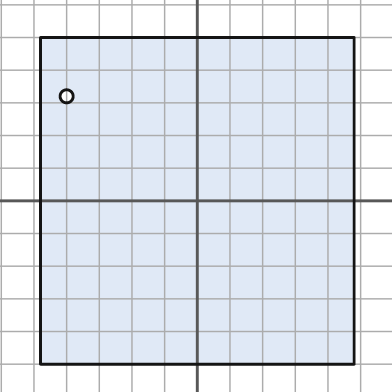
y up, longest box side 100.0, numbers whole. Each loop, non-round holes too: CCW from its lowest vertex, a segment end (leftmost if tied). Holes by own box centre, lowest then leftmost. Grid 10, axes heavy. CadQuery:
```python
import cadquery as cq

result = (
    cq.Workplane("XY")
    .moveTo(-48.0, -50.0)
    .lineTo(48.0, -50.0)
    .lineTo(48.0, 50.0)
    .lineTo(-48.0, 50.0)
    .close()
    .moveTo(-40.0, 32.0)
    .circle(2.0)
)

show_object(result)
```